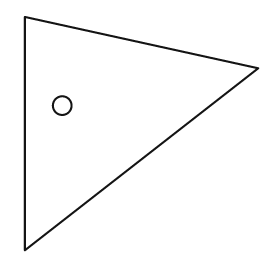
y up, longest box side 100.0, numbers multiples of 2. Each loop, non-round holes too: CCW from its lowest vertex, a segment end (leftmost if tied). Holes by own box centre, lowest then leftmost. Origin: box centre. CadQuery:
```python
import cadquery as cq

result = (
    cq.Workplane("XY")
    .moveTo(-50.0, -50.0)
    .lineTo(50.0, 28.0)
    .lineTo(-50.0, 50.0)
    .close()
    .moveTo(-34.0, 12.0)
    .circle(4.0)
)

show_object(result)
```